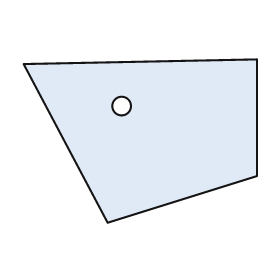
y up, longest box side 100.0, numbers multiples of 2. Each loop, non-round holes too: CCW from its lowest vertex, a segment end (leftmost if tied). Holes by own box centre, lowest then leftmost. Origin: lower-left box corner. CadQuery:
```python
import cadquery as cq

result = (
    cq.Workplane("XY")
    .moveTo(36.0, 0.0)
    .lineTo(100.0, 20.0)
    .lineTo(100.0, 70.0)
    .lineTo(0.0, 68.0)
    .close()
    .moveTo(42.0, 50.0)
    .circle(4.0)
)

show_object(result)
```